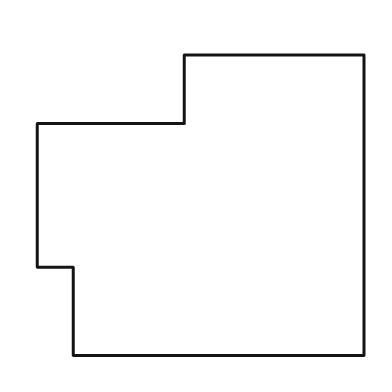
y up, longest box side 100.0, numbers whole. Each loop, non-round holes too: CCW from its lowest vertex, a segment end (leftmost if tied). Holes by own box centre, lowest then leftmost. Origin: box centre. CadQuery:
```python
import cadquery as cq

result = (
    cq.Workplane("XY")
    .moveTo(-39.0, -46.0)
    .lineTo(50.0, -46.0)
    .lineTo(50.0, 46.0)
    .lineTo(-5.0, 46.0)
    .lineTo(-5.0, 25.0)
    .lineTo(-50.0, 25.0)
    .lineTo(-50.0, -19.0)
    .lineTo(-39.0, -19.0)
    .close()
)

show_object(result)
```